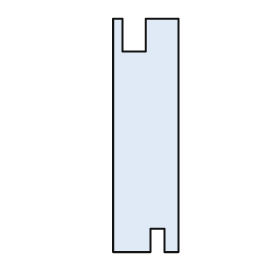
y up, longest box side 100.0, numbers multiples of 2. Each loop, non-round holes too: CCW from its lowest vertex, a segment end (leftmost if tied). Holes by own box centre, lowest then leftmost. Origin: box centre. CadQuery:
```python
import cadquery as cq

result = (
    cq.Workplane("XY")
    .moveTo(-14.0, -50.0)
    .lineTo(2.0, -50.0)
    .lineTo(2.0, -40.0)
    .lineTo(8.0, -40.0)
    .lineTo(8.0, -50.0)
    .lineTo(14.0, -50.0)
    .lineTo(14.0, 50.0)
    .lineTo(0.0, 50.0)
    .lineTo(0.0, 36.0)
    .lineTo(-10.0, 36.0)
    .lineTo(-10.0, 50.0)
    .lineTo(-14.0, 50.0)
    .close()
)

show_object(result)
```